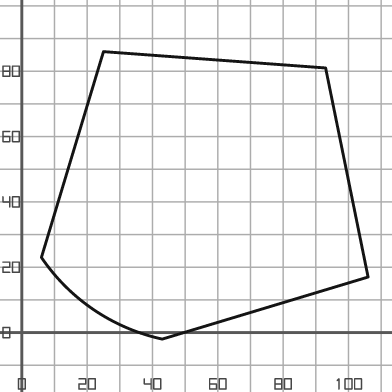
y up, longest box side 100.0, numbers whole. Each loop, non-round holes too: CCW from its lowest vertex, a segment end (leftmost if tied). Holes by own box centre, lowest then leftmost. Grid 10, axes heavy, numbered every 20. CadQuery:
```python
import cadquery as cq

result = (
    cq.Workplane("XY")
    .moveTo(43.0, -2.0)
    .lineTo(106.0, 17.0)
    .lineTo(93.0, 81.0)
    .lineTo(25.0, 86.0)
    .lineTo(6.0, 23.0)
    .threePointArc((22.0, 7.0), (43.0, -2.0))
    .close()
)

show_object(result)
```